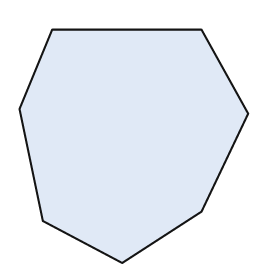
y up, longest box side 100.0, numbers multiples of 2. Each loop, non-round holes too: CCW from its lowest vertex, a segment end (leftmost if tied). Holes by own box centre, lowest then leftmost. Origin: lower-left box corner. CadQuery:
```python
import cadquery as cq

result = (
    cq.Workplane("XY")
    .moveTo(44.0, 0.0)
    .lineTo(78.0, 22.0)
    .lineTo(98.0, 64.0)
    .lineTo(78.0, 100.0)
    .lineTo(14.0, 100.0)
    .lineTo(0.0, 66.0)
    .lineTo(10.0, 18.0)
    .close()
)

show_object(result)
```